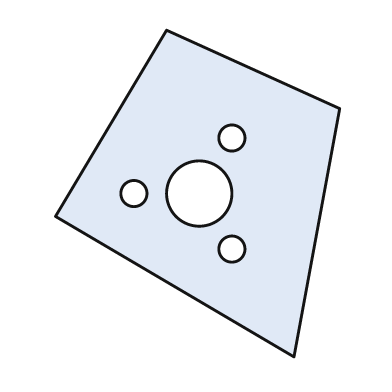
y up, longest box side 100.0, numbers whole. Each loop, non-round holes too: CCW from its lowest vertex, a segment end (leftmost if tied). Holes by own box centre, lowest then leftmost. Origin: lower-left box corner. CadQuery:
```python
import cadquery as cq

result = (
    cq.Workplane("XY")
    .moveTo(73.0, 0.0)
    .lineTo(87.0, 76.0)
    .lineTo(34.0, 100.0)
    .lineTo(0.0, 43.0)
    .close()
    .moveTo(54.0, 33.0)
    .circle(4.0)
    .moveTo(24.0, 50.0)
    .circle(4.0)
    .moveTo(44.0, 50.0)
    .circle(10.0)
    .moveTo(54.0, 67.0)
    .circle(4.0)
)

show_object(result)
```